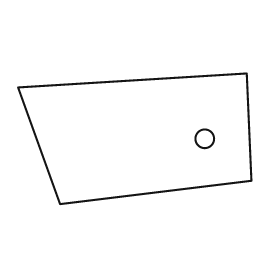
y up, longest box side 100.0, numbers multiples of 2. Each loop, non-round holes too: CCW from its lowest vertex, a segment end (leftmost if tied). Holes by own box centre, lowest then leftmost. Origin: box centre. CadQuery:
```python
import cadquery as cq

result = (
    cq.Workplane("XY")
    .moveTo(-32.0, -28.0)
    .lineTo(50.0, -18.0)
    .lineTo(48.0, 28.0)
    .lineTo(-50.0, 22.0)
    .close()
    .moveTo(30.0, 0.0)
    .circle(4.0)
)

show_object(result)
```